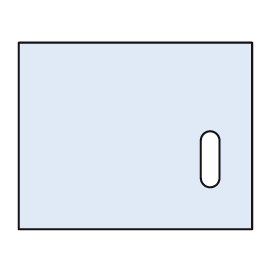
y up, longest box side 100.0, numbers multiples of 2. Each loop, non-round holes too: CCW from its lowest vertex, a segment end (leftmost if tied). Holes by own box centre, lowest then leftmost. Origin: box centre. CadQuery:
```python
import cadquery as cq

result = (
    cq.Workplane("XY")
    .moveTo(-50.0, -40.0)
    .lineTo(50.0, -40.0)
    .lineTo(50.0, 40.0)
    .lineTo(-50.0, 40.0)
    .close()
    .moveTo(28.0, -18.0)
    .threePointArc((32.0, -22.0), (36.0, -18.0))
    .lineTo(36.0, -2.0)
    .threePointArc((32.0, 2.0), (28.0, -2.0))
    .close()
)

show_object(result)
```